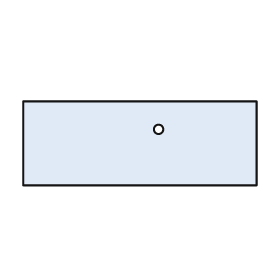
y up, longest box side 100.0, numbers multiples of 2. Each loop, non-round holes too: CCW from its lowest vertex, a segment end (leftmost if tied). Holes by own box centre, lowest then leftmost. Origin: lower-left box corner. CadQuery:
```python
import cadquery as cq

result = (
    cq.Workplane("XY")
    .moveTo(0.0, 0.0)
    .lineTo(100.0, 0.0)
    .lineTo(100.0, 36.0)
    .lineTo(0.0, 36.0)
    .close()
    .moveTo(58.0, 24.0)
    .circle(2.0)
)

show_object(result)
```